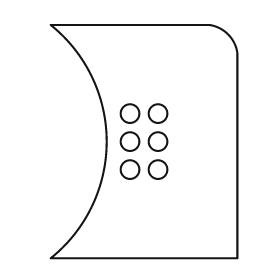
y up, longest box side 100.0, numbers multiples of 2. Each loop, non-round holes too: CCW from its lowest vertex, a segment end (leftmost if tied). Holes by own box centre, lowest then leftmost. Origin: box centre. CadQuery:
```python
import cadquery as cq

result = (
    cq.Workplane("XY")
    .moveTo(-40.0, -50.0)
    .lineTo(40.0, -50.0)
    .lineTo(40.0, 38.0)
    .threePointArc((36.0, 46.0), (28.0, 50.0))
    .lineTo(-40.0, 50.0)
    .threePointArc((-16.0, 0.0), (-40.0, -50.0))
    .close()
    .moveTo(-6.0, -12.0)
    .circle(4.0)
    .moveTo(6.0, -12.0)
    .circle(4.0)
    .moveTo(-6.0, 0.0)
    .circle(4.0)
    .moveTo(6.0, 0.0)
    .circle(4.0)
    .moveTo(-6.0, 12.0)
    .circle(4.0)
    .moveTo(6.0, 12.0)
    .circle(4.0)
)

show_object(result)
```